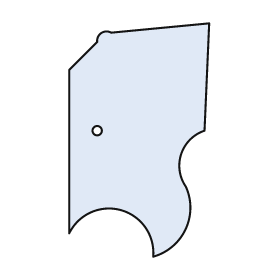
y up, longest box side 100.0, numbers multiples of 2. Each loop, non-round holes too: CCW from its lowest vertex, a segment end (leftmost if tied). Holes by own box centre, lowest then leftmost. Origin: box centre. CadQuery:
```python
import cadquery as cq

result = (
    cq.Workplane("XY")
    .moveTo(6.0, -50.0)
    .threePointArc((20.0, -38.0), (20.0, -20.0))
    .threePointArc((18.0, -6.0), (28.0, 4.0))
    .lineTo(30.0, 50.0)
    .lineTo(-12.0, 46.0)
    .threePointArc((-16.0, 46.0), (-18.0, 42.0))
    .lineTo(-30.0, 30.0)
    .lineTo(-30.0, -40.0)
    .threePointArc((-8.0, -30.0), (6.0, -50.0))
    .close()
    .moveTo(-18.0, 4.0)
    .circle(2.0)
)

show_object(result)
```